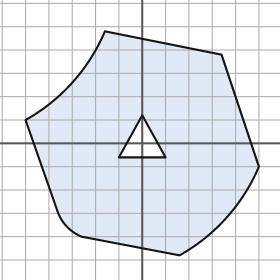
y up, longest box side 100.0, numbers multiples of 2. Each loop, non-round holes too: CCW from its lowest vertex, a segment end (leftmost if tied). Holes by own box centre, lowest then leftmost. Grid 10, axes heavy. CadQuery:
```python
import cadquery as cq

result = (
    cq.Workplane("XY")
    .moveTo(16.0, -48.0)
    .threePointArc((36.0, -32.0), (50.0, -10.0))
    .lineTo(34.0, 38.0)
    .lineTo(-16.0, 48.0)
    .threePointArc((-30.0, 26.0), (-50.0, 10.0))
    .lineTo(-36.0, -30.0)
    .threePointArc((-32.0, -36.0), (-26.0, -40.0))
    .close()
    .moveTo(-10.0, -6.0)
    .lineTo(10.0, -6.0)
    .lineTo(0.0, 12.0)
    .close()
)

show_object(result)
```